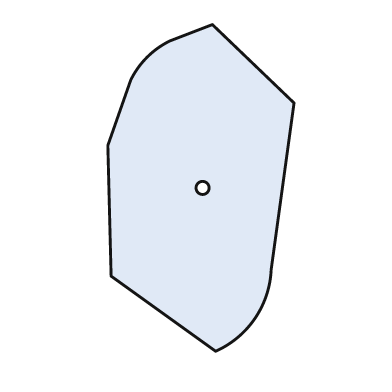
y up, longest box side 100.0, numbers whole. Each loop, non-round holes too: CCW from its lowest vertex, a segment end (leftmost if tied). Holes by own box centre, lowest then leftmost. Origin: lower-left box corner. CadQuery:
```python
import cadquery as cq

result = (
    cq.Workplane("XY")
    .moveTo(33.0, 0.0)
    .threePointArc((45.0, 10.0), (50.0, 25.0))
    .lineTo(57.0, 76.0)
    .lineTo(32.0, 100.0)
    .lineTo(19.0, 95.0)
    .threePointArc((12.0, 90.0), (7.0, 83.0))
    .lineTo(0.0, 63.0)
    .lineTo(1.0, 23.0)
    .close()
    .moveTo(29.0, 50.0)
    .circle(2.0)
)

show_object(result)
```